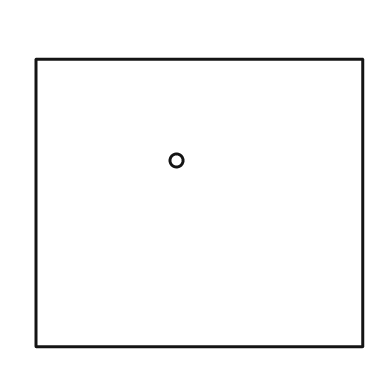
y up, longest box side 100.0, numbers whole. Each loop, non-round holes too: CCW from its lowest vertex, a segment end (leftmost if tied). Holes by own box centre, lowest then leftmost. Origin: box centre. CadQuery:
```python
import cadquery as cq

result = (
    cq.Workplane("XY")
    .moveTo(-50.0, -44.0)
    .lineTo(50.0, -44.0)
    .lineTo(50.0, 44.0)
    .lineTo(-50.0, 44.0)
    .close()
    .moveTo(-7.0, 13.0)
    .circle(2.0)
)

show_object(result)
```